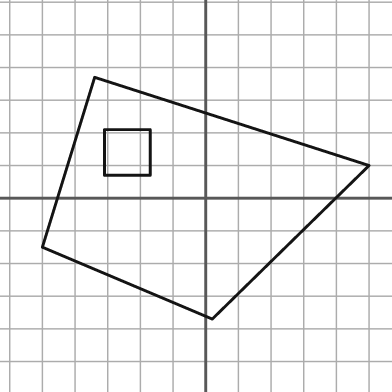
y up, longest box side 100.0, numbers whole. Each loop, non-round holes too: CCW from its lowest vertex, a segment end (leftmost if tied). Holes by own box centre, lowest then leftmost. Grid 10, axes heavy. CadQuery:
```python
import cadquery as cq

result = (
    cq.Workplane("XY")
    .moveTo(2.0, -37.0)
    .lineTo(50.0, 10.0)
    .lineTo(-34.0, 37.0)
    .lineTo(-50.0, -15.0)
    .close()
    .moveTo(-31.0, 7.0)
    .lineTo(-17.0, 7.0)
    .lineTo(-17.0, 21.0)
    .lineTo(-31.0, 21.0)
    .close()
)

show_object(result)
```